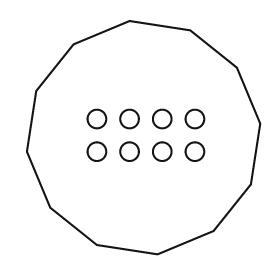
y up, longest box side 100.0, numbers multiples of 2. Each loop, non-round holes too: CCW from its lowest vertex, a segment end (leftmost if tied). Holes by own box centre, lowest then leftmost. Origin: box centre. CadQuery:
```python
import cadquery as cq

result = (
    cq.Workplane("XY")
    .moveTo(6.0, -50.0)
    .lineTo(30.0, -40.0)
    .lineTo(46.0, -20.0)
    .lineTo(50.0, 6.0)
    .lineTo(40.0, 30.0)
    .lineTo(20.0, 46.0)
    .lineTo(-6.0, 50.0)
    .lineTo(-30.0, 40.0)
    .lineTo(-46.0, 20.0)
    .lineTo(-50.0, -6.0)
    .lineTo(-40.0, -30.0)
    .lineTo(-20.0, -46.0)
    .close()
    .moveTo(-20.0, -6.0)
    .circle(4.0)
    .moveTo(-6.0, -6.0)
    .circle(4.0)
    .moveTo(8.0, -6.0)
    .circle(4.0)
    .moveTo(22.0, -6.0)
    .circle(4.0)
    .moveTo(-20.0, 8.0)
    .circle(4.0)
    .moveTo(-6.0, 8.0)
    .circle(4.0)
    .moveTo(8.0, 8.0)
    .circle(4.0)
    .moveTo(22.0, 8.0)
    .circle(4.0)
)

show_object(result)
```